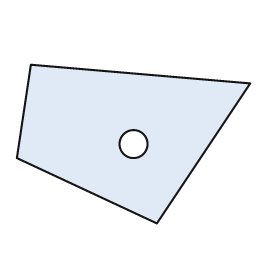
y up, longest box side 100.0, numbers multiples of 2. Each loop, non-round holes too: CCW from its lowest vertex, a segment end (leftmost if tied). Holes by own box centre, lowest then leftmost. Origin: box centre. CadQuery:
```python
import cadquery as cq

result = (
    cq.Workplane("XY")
    .moveTo(10.0, -34.0)
    .lineTo(50.0, 26.0)
    .lineTo(-44.0, 34.0)
    .lineTo(-50.0, -6.0)
    .close()
    .moveTo(0.0, 0.0)
    .circle(6.0)
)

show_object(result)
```